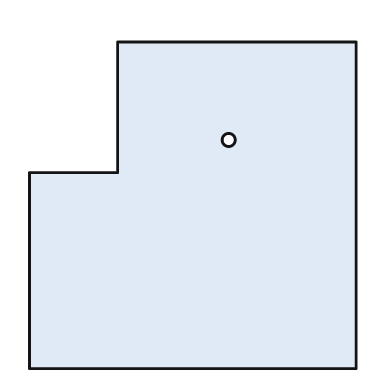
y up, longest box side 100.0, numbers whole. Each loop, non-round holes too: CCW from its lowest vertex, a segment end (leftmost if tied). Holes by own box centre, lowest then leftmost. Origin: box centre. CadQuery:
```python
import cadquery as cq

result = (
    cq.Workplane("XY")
    .moveTo(-50.0, -50.0)
    .lineTo(50.0, -50.0)
    .lineTo(50.0, 50.0)
    .lineTo(-23.0, 50.0)
    .lineTo(-23.0, 10.0)
    .lineTo(-50.0, 10.0)
    .close()
    .moveTo(11.0, 20.0)
    .circle(2.0)
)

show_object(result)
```